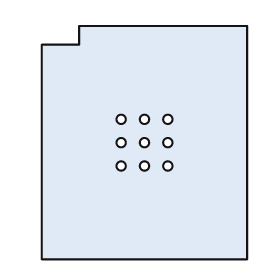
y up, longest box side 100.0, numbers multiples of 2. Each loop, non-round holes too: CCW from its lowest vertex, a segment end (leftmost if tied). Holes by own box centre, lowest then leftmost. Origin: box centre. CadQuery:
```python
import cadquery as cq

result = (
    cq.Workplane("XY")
    .moveTo(-44.0, -50.0)
    .lineTo(44.0, -50.0)
    .lineTo(44.0, 50.0)
    .lineTo(-28.0, 50.0)
    .lineTo(-28.0, 42.0)
    .lineTo(-44.0, 42.0)
    .close()
    .moveTo(-10.0, -10.0)
    .circle(2.0)
    .moveTo(0.0, -10.0)
    .circle(2.0)
    .moveTo(10.0, -10.0)
    .circle(2.0)
    .moveTo(-10.0, 0.0)
    .circle(2.0)
    .moveTo(0.0, 0.0)
    .circle(2.0)
    .moveTo(10.0, 0.0)
    .circle(2.0)
    .moveTo(-10.0, 10.0)
    .circle(2.0)
    .moveTo(0.0, 10.0)
    .circle(2.0)
    .moveTo(10.0, 10.0)
    .circle(2.0)
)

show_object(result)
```